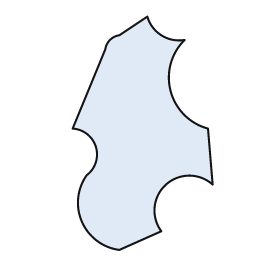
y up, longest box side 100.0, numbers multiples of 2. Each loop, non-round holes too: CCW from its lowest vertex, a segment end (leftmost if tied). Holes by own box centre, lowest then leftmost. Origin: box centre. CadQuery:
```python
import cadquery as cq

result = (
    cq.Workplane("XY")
    .moveTo(-10.0, -50.0)
    .lineTo(8.0, -42.0)
    .threePointArc((10.0, -22.0), (30.0, -22.0))
    .lineTo(28.0, 2.0)
    .threePointArc((12.0, 18.0), (18.0, 40.0))
    .threePointArc((8.0, 42.0), (2.0, 50.0))
    .lineTo(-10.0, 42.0)
    .threePointArc((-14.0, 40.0), (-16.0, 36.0))
    .lineTo(-30.0, 2.0)
    .threePointArc((-20.0, -6.0), (-24.0, -18.0))
    .threePointArc((-26.0, -38.0), (-10.0, -50.0))
    .close()
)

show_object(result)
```